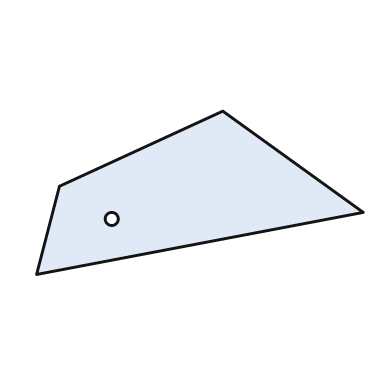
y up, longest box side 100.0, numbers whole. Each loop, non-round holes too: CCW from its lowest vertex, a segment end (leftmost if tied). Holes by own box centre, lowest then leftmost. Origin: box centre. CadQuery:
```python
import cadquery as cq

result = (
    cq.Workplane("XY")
    .moveTo(-50.0, -25.0)
    .lineTo(50.0, -6.0)
    .lineTo(7.0, 25.0)
    .lineTo(-43.0, 2.0)
    .close()
    .moveTo(-27.0, -8.0)
    .circle(2.0)
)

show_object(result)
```